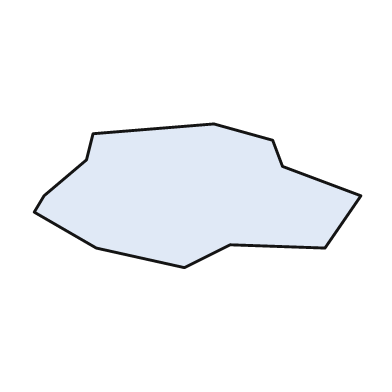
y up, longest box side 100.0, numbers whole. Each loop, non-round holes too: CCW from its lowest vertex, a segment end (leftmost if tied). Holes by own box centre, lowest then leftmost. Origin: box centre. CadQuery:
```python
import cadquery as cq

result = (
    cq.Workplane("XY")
    .moveTo(-4.0, -22.0)
    .lineTo(10.0, -15.0)
    .lineTo(39.0, -16.0)
    .lineTo(50.0, 0.0)
    .lineTo(26.0, 9.0)
    .lineTo(23.0, 17.0)
    .lineTo(5.0, 22.0)
    .lineTo(-32.0, 19.0)
    .lineTo(-34.0, 11.0)
    .lineTo(-47.0, 0.0)
    .lineTo(-50.0, -5.0)
    .lineTo(-31.0, -16.0)
    .close()
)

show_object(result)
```